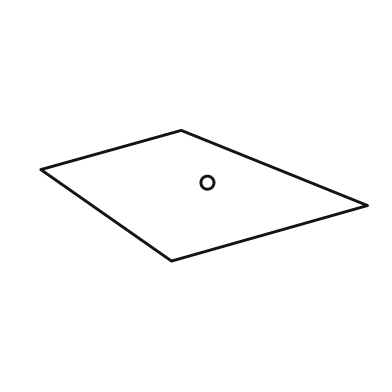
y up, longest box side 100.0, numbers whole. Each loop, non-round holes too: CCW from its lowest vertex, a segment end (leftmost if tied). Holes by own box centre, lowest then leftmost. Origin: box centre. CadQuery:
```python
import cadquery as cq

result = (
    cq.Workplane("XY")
    .moveTo(-10.0, -20.0)
    .lineTo(50.0, -3.0)
    .lineTo(-7.0, 20.0)
    .lineTo(-50.0, 8.0)
    .close()
    .moveTo(1.0, 4.0)
    .circle(2.0)
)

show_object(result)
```